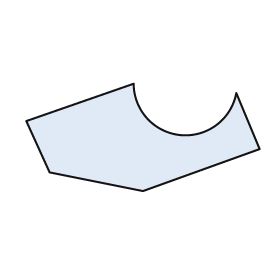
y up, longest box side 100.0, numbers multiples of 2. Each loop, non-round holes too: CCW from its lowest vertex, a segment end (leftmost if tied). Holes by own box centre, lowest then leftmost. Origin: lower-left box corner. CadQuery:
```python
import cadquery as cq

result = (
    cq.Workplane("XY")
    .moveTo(50.0, 0.0)
    .lineTo(100.0, 18.0)
    .lineTo(90.0, 42.0)
    .threePointArc((66.0, 24.0), (46.0, 46.0))
    .lineTo(0.0, 30.0)
    .lineTo(10.0, 8.0)
    .close()
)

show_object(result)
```